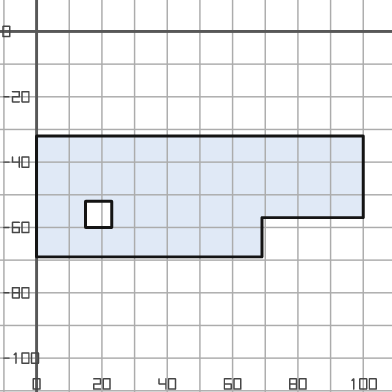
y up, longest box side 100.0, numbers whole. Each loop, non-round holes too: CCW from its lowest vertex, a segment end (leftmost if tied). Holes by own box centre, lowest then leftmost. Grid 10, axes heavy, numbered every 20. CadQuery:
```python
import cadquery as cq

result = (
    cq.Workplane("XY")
    .moveTo(0.0, -69.0)
    .lineTo(69.0, -69.0)
    .lineTo(69.0, -57.0)
    .lineTo(100.0, -57.0)
    .lineTo(100.0, -32.0)
    .lineTo(0.0, -32.0)
    .close()
    .moveTo(15.0, -60.0)
    .lineTo(23.0, -60.0)
    .lineTo(23.0, -52.0)
    .lineTo(15.0, -52.0)
    .close()
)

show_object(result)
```